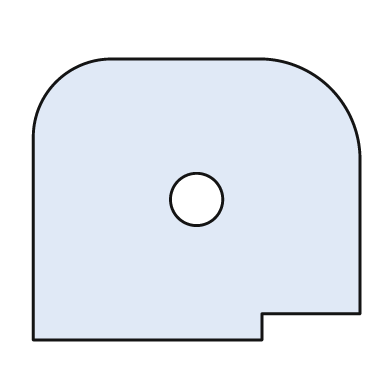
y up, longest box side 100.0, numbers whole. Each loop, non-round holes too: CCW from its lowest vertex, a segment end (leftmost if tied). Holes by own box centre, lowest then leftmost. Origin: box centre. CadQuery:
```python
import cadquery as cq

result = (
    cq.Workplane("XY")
    .moveTo(-50.0, -43.0)
    .lineTo(20.0, -43.0)
    .lineTo(20.0, -35.0)
    .lineTo(50.0, -35.0)
    .lineTo(50.0, 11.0)
    .threePointArc((41.0, 34.0), (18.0, 43.0))
    .lineTo(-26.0, 43.0)
    .threePointArc((-43.0, 36.0), (-50.0, 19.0))
    .close()
    .moveTo(0.0, 0.0)
    .circle(8.0)
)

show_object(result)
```